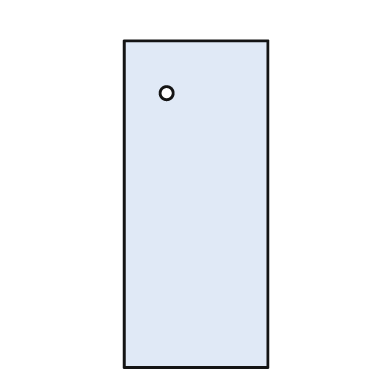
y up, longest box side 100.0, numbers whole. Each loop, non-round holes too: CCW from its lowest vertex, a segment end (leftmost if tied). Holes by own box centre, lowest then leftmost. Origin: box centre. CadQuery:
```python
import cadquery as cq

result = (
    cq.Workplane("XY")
    .moveTo(-22.0, -50.0)
    .lineTo(22.0, -50.0)
    .lineTo(22.0, 50.0)
    .lineTo(-22.0, 50.0)
    .close()
    .moveTo(-9.0, 34.0)
    .circle(2.0)
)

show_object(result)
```